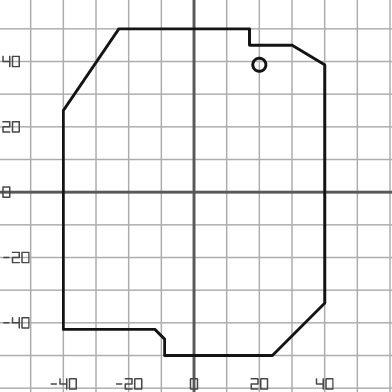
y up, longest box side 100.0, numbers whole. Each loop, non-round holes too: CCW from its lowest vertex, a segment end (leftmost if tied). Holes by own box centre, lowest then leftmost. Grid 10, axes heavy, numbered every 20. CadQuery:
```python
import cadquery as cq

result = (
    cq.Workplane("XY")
    .moveTo(-9.0, -50.0)
    .lineTo(24.0, -50.0)
    .lineTo(40.0, -34.0)
    .lineTo(40.0, 39.0)
    .lineTo(30.0, 45.0)
    .lineTo(17.0, 45.0)
    .lineTo(17.0, 50.0)
    .lineTo(-23.0, 50.0)
    .lineTo(-40.0, 25.0)
    .lineTo(-40.0, -42.0)
    .lineTo(-12.0, -42.0)
    .lineTo(-9.0, -45.0)
    .close()
    .moveTo(20.0, 39.0)
    .circle(2.0)
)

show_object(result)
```